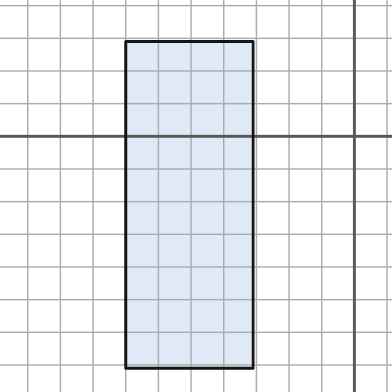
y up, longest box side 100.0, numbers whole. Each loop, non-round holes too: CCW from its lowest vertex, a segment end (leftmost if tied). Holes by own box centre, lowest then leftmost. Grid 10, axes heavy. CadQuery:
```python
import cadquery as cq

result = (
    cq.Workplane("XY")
    .moveTo(-70.0, -71.0)
    .lineTo(-31.0, -71.0)
    .lineTo(-31.0, 29.0)
    .lineTo(-70.0, 29.0)
    .close()
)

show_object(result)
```